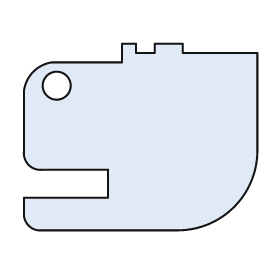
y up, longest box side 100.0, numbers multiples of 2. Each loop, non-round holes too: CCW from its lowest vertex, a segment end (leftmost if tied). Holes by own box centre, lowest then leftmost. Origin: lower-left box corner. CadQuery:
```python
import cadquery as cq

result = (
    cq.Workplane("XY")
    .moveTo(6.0, 0.0)
    .lineTo(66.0, 0.0)
    .threePointArc((90.0, 10.0), (100.0, 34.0))
    .lineTo(100.0, 76.0)
    .lineTo(68.0, 76.0)
    .lineTo(68.0, 80.0)
    .lineTo(56.0, 80.0)
    .lineTo(56.0, 76.0)
    .lineTo(48.0, 76.0)
    .lineTo(48.0, 80.0)
    .lineTo(42.0, 80.0)
    .lineTo(42.0, 72.0)
    .lineTo(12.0, 72.0)
    .threePointArc((4.0, 68.0), (0.0, 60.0))
    .lineTo(0.0, 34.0)
    .threePointArc((2.0, 28.0), (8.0, 26.0))
    .lineTo(36.0, 26.0)
    .lineTo(36.0, 14.0)
    .lineTo(0.0, 14.0)
    .lineTo(0.0, 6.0)
    .threePointArc((2.0, 2.0), (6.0, 0.0))
    .close()
    .moveTo(14.0, 62.0)
    .circle(6.0)
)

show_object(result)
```